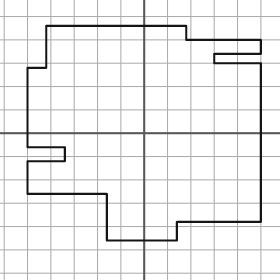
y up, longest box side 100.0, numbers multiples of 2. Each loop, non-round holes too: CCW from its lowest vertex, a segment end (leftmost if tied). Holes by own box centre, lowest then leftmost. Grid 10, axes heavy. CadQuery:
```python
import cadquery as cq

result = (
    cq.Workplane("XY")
    .moveTo(-16.0, -46.0)
    .lineTo(14.0, -46.0)
    .lineTo(14.0, -38.0)
    .lineTo(50.0, -38.0)
    .lineTo(50.0, 30.0)
    .lineTo(30.0, 30.0)
    .lineTo(30.0, 34.0)
    .lineTo(50.0, 34.0)
    .lineTo(50.0, 40.0)
    .lineTo(18.0, 40.0)
    .lineTo(18.0, 46.0)
    .lineTo(-42.0, 46.0)
    .lineTo(-42.0, 28.0)
    .lineTo(-50.0, 28.0)
    .lineTo(-50.0, -6.0)
    .lineTo(-34.0, -6.0)
    .lineTo(-34.0, -12.0)
    .lineTo(-50.0, -12.0)
    .lineTo(-50.0, -26.0)
    .lineTo(-16.0, -26.0)
    .close()
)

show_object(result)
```